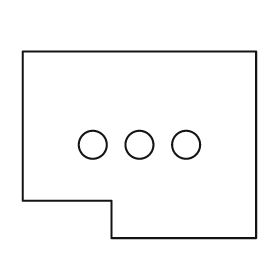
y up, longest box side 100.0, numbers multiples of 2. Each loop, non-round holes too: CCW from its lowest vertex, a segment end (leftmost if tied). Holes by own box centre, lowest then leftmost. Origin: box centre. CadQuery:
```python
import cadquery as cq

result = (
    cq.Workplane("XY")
    .moveTo(-12.0, -40.0)
    .lineTo(50.0, -40.0)
    .lineTo(50.0, 40.0)
    .lineTo(-50.0, 40.0)
    .lineTo(-50.0, -24.0)
    .lineTo(-12.0, -24.0)
    .close()
    .moveTo(-20.0, 0.0)
    .circle(6.0)
    .moveTo(0.0, 0.0)
    .circle(6.0)
    .moveTo(20.0, 0.0)
    .circle(6.0)
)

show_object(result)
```